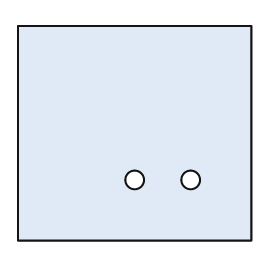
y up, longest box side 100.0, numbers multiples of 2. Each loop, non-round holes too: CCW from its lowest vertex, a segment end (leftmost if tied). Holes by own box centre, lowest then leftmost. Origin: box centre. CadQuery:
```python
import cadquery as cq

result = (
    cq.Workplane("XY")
    .moveTo(-50.0, -46.0)
    .lineTo(50.0, -46.0)
    .lineTo(50.0, 46.0)
    .lineTo(-50.0, 46.0)
    .close()
    .moveTo(0.0, -20.0)
    .circle(4.0)
    .moveTo(24.0, -20.0)
    .circle(4.0)
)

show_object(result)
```